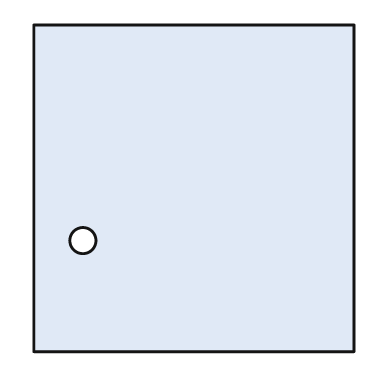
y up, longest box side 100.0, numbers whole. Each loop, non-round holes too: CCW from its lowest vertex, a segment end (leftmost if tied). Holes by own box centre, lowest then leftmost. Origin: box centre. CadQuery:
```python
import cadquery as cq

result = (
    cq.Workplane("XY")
    .moveTo(-49.0, -50.0)
    .lineTo(49.0, -50.0)
    .lineTo(49.0, 50.0)
    .lineTo(-49.0, 50.0)
    .close()
    .moveTo(-34.0, -16.0)
    .circle(4.0)
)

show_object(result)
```